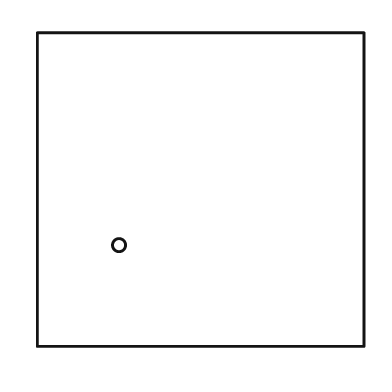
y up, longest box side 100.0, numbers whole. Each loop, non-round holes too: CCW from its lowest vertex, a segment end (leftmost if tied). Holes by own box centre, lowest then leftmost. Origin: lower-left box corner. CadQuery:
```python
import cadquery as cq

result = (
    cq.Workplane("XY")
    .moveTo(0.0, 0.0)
    .lineTo(100.0, 0.0)
    .lineTo(100.0, 96.0)
    .lineTo(0.0, 96.0)
    .close()
    .moveTo(25.0, 31.0)
    .circle(2.0)
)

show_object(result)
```